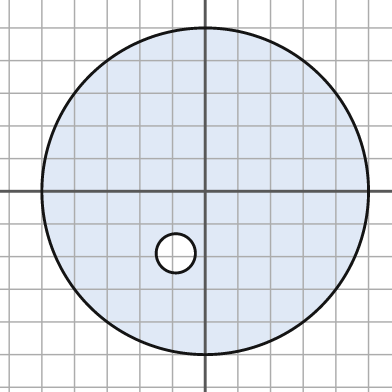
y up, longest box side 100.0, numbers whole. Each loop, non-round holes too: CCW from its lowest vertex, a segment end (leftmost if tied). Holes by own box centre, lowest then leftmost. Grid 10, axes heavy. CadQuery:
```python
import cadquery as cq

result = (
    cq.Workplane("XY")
    .moveTo(0.0, 0.0)
    .circle(50.0)
    .moveTo(-9.0, -19.0)
    .circle(6.0)
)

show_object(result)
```